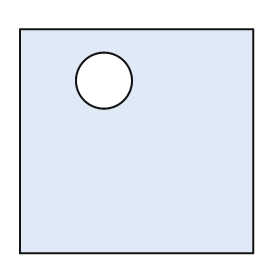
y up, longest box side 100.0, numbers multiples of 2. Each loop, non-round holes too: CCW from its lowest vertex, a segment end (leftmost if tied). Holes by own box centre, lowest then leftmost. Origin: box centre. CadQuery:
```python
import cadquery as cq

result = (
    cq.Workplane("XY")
    .moveTo(-50.0, -48.0)
    .lineTo(50.0, -48.0)
    .lineTo(50.0, 48.0)
    .lineTo(-50.0, 48.0)
    .close()
    .moveTo(-14.0, 26.0)
    .circle(12.0)
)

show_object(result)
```